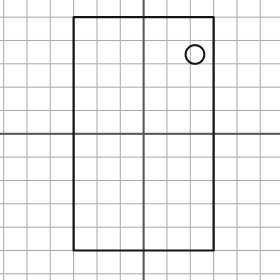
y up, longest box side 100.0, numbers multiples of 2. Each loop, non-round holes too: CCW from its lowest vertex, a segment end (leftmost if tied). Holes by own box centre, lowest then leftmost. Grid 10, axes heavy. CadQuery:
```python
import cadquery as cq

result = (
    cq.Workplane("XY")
    .moveTo(-30.0, -50.0)
    .lineTo(30.0, -50.0)
    .lineTo(30.0, 50.0)
    .lineTo(-30.0, 50.0)
    .close()
    .moveTo(22.0, 34.0)
    .circle(4.0)
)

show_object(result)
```